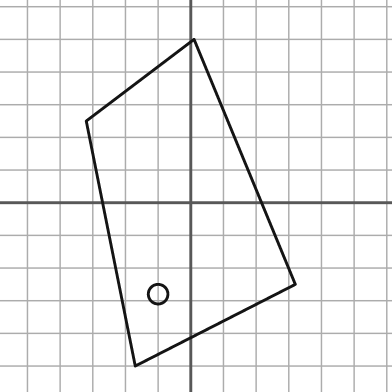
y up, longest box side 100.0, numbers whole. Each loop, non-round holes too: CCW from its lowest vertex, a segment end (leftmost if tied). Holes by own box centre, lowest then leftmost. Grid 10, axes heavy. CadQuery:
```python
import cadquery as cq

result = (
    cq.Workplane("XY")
    .moveTo(-17.0, -50.0)
    .lineTo(32.0, -25.0)
    .lineTo(1.0, 50.0)
    .lineTo(-32.0, 25.0)
    .close()
    .moveTo(-10.0, -28.0)
    .circle(3.0)
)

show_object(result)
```